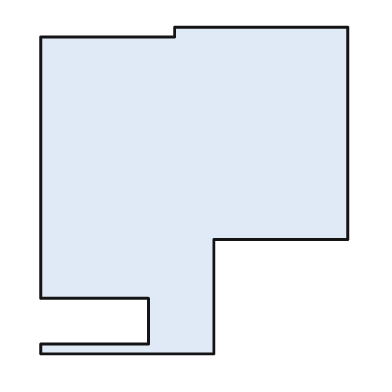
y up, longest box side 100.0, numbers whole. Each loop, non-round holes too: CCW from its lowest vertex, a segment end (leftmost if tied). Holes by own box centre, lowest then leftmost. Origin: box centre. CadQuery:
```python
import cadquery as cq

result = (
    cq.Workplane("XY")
    .moveTo(-47.0, -50.0)
    .lineTo(6.0, -50.0)
    .lineTo(6.0, -15.0)
    .lineTo(47.0, -15.0)
    .lineTo(47.0, 50.0)
    .lineTo(-6.0, 50.0)
    .lineTo(-6.0, 47.0)
    .lineTo(-47.0, 47.0)
    .lineTo(-47.0, -33.0)
    .lineTo(-14.0, -33.0)
    .lineTo(-14.0, -47.0)
    .lineTo(-47.0, -47.0)
    .close()
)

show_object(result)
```